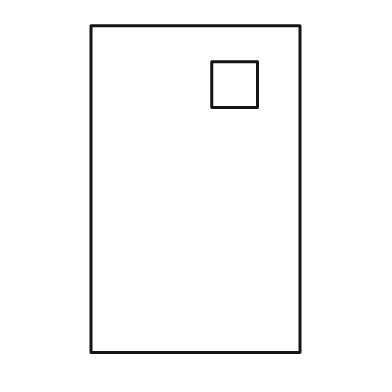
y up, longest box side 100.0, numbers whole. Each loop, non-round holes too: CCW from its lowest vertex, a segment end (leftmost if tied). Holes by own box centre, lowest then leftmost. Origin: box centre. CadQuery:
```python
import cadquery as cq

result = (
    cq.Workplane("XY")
    .moveTo(-32.0, -50.0)
    .lineTo(32.0, -50.0)
    .lineTo(32.0, 50.0)
    .lineTo(-32.0, 50.0)
    .close()
    .moveTo(5.0, 25.0)
    .lineTo(19.0, 25.0)
    .lineTo(19.0, 39.0)
    .lineTo(5.0, 39.0)
    .close()
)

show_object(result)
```